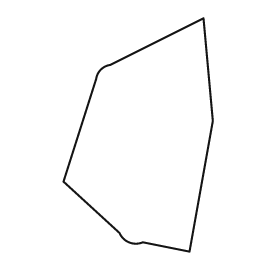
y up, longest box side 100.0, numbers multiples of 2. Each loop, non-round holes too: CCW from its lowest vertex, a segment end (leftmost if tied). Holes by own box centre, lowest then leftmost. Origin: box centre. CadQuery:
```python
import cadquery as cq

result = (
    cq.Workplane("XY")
    .moveTo(22.0, -50.0)
    .lineTo(32.0, 6.0)
    .lineTo(28.0, 50.0)
    .lineTo(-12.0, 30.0)
    .threePointArc((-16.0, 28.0), (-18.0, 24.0))
    .lineTo(-32.0, -20.0)
    .lineTo(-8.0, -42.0)
    .threePointArc((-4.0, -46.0), (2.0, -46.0))
    .close()
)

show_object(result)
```